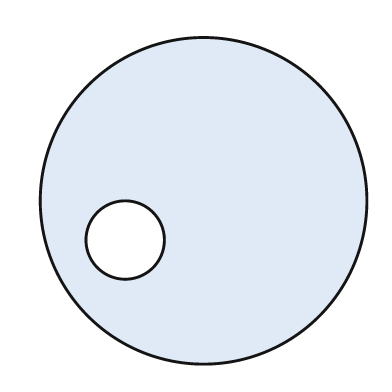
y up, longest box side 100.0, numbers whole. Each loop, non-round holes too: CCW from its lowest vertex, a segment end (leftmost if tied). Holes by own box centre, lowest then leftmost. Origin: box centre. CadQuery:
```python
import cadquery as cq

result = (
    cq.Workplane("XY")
    .moveTo(0.0, 0.0)
    .circle(50.0)
    .moveTo(-24.0, -12.0)
    .circle(12.0)
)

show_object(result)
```